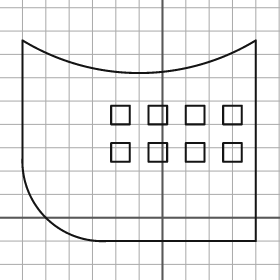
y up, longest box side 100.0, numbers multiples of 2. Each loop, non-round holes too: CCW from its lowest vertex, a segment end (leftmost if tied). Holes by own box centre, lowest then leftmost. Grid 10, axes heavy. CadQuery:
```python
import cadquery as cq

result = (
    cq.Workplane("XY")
    .moveTo(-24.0, -10.0)
    .lineTo(40.0, -10.0)
    .lineTo(40.0, 76.0)
    .threePointArc((-10.0, 62.0), (-60.0, 76.0))
    .lineTo(-60.0, 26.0)
    .threePointArc((-50.0, 0.0), (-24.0, -10.0))
    .close()
    .moveTo(-22.0, 24.0)
    .lineTo(-14.0, 24.0)
    .lineTo(-14.0, 32.0)
    .lineTo(-22.0, 32.0)
    .close()
    .moveTo(-6.0, 24.0)
    .lineTo(2.0, 24.0)
    .lineTo(2.0, 32.0)
    .lineTo(-6.0, 32.0)
    .close()
    .moveTo(10.0, 24.0)
    .lineTo(18.0, 24.0)
    .lineTo(18.0, 32.0)
    .lineTo(10.0, 32.0)
    .close()
    .moveTo(26.0, 24.0)
    .lineTo(34.0, 24.0)
    .lineTo(34.0, 32.0)
    .lineTo(26.0, 32.0)
    .close()
    .moveTo(-22.0, 40.0)
    .lineTo(-14.0, 40.0)
    .lineTo(-14.0, 48.0)
    .lineTo(-22.0, 48.0)
    .close()
    .moveTo(-6.0, 40.0)
    .lineTo(2.0, 40.0)
    .lineTo(2.0, 48.0)
    .lineTo(-6.0, 48.0)
    .close()
    .moveTo(10.0, 40.0)
    .lineTo(18.0, 40.0)
    .lineTo(18.0, 48.0)
    .lineTo(10.0, 48.0)
    .close()
    .moveTo(26.0, 40.0)
    .lineTo(34.0, 40.0)
    .lineTo(34.0, 48.0)
    .lineTo(26.0, 48.0)
    .close()
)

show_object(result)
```